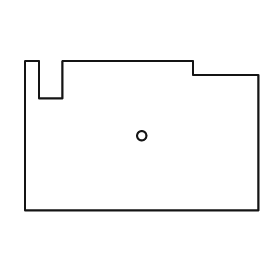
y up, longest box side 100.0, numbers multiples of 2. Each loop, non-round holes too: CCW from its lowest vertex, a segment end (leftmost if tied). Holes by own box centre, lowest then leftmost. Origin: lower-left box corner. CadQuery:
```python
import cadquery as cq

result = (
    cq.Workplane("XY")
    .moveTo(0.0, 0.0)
    .lineTo(100.0, 0.0)
    .lineTo(100.0, 58.0)
    .lineTo(72.0, 58.0)
    .lineTo(72.0, 64.0)
    .lineTo(16.0, 64.0)
    .lineTo(16.0, 48.0)
    .lineTo(6.0, 48.0)
    .lineTo(6.0, 64.0)
    .lineTo(0.0, 64.0)
    .close()
    .moveTo(50.0, 32.0)
    .circle(2.0)
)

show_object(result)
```